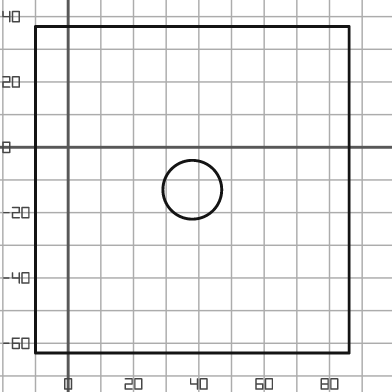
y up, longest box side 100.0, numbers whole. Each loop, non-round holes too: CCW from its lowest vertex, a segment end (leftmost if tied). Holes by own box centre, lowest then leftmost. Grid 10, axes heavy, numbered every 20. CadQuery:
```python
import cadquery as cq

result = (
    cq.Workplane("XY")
    .moveTo(-10.0, -63.0)
    .lineTo(86.0, -63.0)
    .lineTo(86.0, 37.0)
    .lineTo(-10.0, 37.0)
    .close()
    .moveTo(38.0, -13.0)
    .circle(9.0)
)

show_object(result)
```